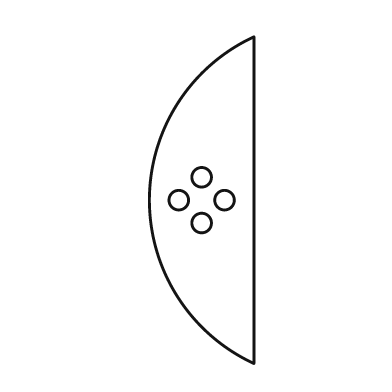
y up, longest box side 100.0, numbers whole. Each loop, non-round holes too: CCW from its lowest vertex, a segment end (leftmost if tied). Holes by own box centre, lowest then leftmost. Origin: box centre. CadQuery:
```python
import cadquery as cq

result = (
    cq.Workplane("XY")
    .moveTo(16.0, -50.0)
    .lineTo(16.0, 50.0)
    .threePointArc((-16.0, 0.0), (16.0, -50.0))
    .close()
    .moveTo(0.0, -7.0)
    .circle(3.0)
    .moveTo(-7.0, 0.0)
    .circle(3.0)
    .moveTo(7.0, 0.0)
    .circle(3.0)
    .moveTo(0.0, 7.0)
    .circle(3.0)
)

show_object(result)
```